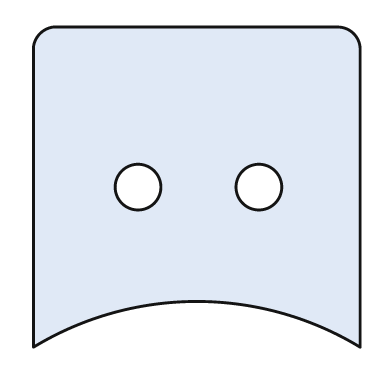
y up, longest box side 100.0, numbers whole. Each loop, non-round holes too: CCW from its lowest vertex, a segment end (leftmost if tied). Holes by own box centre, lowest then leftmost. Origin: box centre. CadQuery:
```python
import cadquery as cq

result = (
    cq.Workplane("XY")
    .moveTo(-50.0, -49.0)
    .threePointArc((0.0, -35.0), (50.0, -49.0))
    .lineTo(50.0, 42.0)
    .threePointArc((48.0, 47.0), (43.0, 49.0))
    .lineTo(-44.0, 49.0)
    .threePointArc((-48.0, 47.0), (-50.0, 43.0))
    .close()
    .moveTo(-18.0, 0.0)
    .circle(7.0)
    .moveTo(19.0, 0.0)
    .circle(7.0)
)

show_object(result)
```